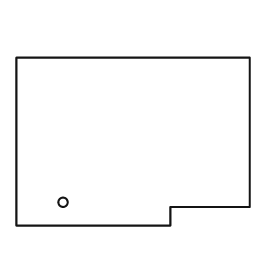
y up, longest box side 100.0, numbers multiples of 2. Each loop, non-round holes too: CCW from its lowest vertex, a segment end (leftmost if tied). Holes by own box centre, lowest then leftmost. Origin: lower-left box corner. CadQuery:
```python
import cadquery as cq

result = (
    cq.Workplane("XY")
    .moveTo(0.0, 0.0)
    .lineTo(66.0, 0.0)
    .lineTo(66.0, 8.0)
    .lineTo(100.0, 8.0)
    .lineTo(100.0, 72.0)
    .lineTo(0.0, 72.0)
    .close()
    .moveTo(20.0, 10.0)
    .circle(2.0)
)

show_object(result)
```